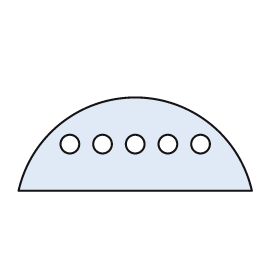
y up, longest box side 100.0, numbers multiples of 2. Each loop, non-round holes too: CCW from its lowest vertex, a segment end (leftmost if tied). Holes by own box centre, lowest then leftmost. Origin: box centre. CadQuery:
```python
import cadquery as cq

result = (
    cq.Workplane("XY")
    .moveTo(-50.0, -20.0)
    .lineTo(50.0, -20.0)
    .threePointArc((0.0, 20.0), (-50.0, -20.0))
    .close()
    .moveTo(-28.0, 0.0)
    .circle(4.0)
    .moveTo(-14.0, 0.0)
    .circle(4.0)
    .moveTo(0.0, 0.0)
    .circle(4.0)
    .moveTo(14.0, 0.0)
    .circle(4.0)
    .moveTo(28.0, 0.0)
    .circle(4.0)
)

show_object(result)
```